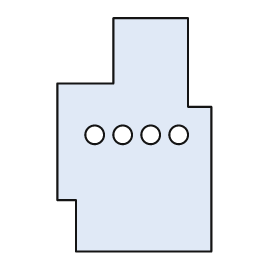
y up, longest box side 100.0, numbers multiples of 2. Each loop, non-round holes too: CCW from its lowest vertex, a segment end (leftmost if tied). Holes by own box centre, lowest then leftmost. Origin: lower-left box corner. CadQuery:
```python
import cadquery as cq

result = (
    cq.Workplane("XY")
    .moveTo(8.0, 0.0)
    .lineTo(66.0, 0.0)
    .lineTo(66.0, 62.0)
    .lineTo(56.0, 62.0)
    .lineTo(56.0, 100.0)
    .lineTo(24.0, 100.0)
    .lineTo(24.0, 72.0)
    .lineTo(0.0, 72.0)
    .lineTo(0.0, 22.0)
    .lineTo(8.0, 22.0)
    .close()
    .moveTo(16.0, 50.0)
    .circle(4.0)
    .moveTo(28.0, 50.0)
    .circle(4.0)
    .moveTo(40.0, 50.0)
    .circle(4.0)
    .moveTo(52.0, 50.0)
    .circle(4.0)
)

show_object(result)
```